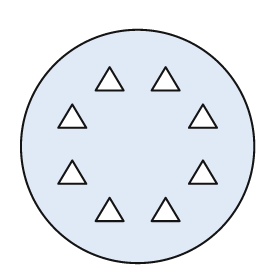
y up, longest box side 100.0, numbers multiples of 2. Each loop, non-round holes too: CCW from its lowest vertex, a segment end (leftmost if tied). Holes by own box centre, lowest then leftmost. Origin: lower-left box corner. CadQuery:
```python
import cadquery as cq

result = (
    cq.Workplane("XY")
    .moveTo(50.0, 50.0)
    .circle(50.0)
    .moveTo(32.0, 18.0)
    .lineTo(44.0, 18.0)
    .lineTo(38.0, 28.0)
    .close()
    .moveTo(56.0, 18.0)
    .lineTo(68.0, 18.0)
    .lineTo(62.0, 28.0)
    .close()
    .moveTo(16.0, 34.0)
    .lineTo(28.0, 34.0)
    .lineTo(22.0, 44.0)
    .close()
    .moveTo(72.0, 34.0)
    .lineTo(84.0, 34.0)
    .lineTo(78.0, 44.0)
    .close()
    .moveTo(16.0, 58.0)
    .lineTo(28.0, 58.0)
    .lineTo(22.0, 68.0)
    .close()
    .moveTo(72.0, 58.0)
    .lineTo(84.0, 58.0)
    .lineTo(78.0, 68.0)
    .close()
    .moveTo(32.0, 74.0)
    .lineTo(44.0, 74.0)
    .lineTo(38.0, 84.0)
    .close()
    .moveTo(56.0, 74.0)
    .lineTo(68.0, 74.0)
    .lineTo(62.0, 84.0)
    .close()
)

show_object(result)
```